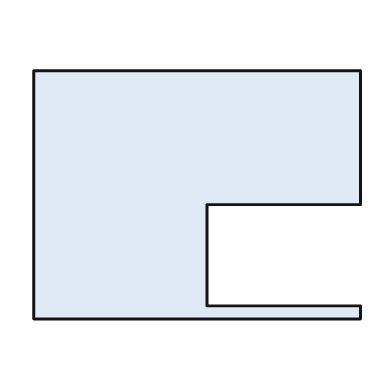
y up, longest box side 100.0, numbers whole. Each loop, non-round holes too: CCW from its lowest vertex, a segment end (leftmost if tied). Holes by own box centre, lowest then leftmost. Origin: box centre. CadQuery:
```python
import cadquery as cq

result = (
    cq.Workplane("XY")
    .moveTo(-50.0, -38.0)
    .lineTo(50.0, -38.0)
    .lineTo(50.0, -34.0)
    .lineTo(3.0, -34.0)
    .lineTo(3.0, -3.0)
    .lineTo(50.0, -3.0)
    .lineTo(50.0, 38.0)
    .lineTo(-50.0, 38.0)
    .close()
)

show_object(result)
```